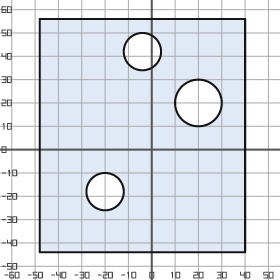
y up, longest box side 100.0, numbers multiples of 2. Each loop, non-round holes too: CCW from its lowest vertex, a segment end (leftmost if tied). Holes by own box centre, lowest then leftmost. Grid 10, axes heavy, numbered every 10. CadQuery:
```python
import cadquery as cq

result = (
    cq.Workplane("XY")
    .moveTo(-48.0, -44.0)
    .lineTo(40.0, -44.0)
    .lineTo(40.0, 56.0)
    .lineTo(-48.0, 56.0)
    .close()
    .moveTo(-20.0, -18.0)
    .circle(8.0)
    .moveTo(20.0, 20.0)
    .circle(10.0)
    .moveTo(-4.0, 42.0)
    .circle(8.0)
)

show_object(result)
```